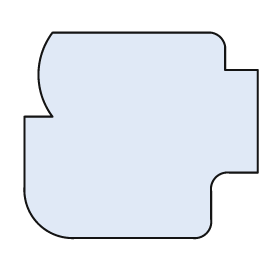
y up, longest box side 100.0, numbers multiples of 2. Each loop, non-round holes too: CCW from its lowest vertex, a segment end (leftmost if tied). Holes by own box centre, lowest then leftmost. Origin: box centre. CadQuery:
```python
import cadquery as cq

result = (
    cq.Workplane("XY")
    .moveTo(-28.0, -44.0)
    .lineTo(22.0, -44.0)
    .threePointArc((28.0, -42.0), (30.0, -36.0))
    .lineTo(30.0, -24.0)
    .threePointArc((32.0, -18.0), (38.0, -16.0))
    .lineTo(50.0, -16.0)
    .lineTo(50.0, 28.0)
    .lineTo(36.0, 28.0)
    .lineTo(36.0, 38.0)
    .threePointArc((34.0, 42.0), (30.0, 44.0))
    .lineTo(-38.0, 44.0)
    .threePointArc((-44.0, 26.0), (-38.0, 8.0))
    .lineTo(-50.0, 8.0)
    .lineTo(-50.0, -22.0)
    .threePointArc((-44.0, -38.0), (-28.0, -44.0))
    .close()
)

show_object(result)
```